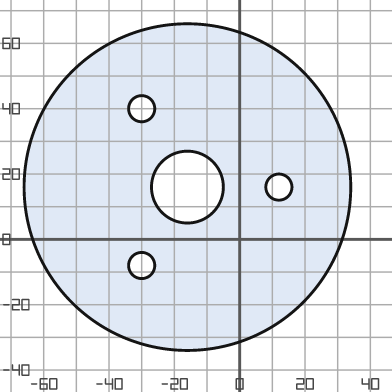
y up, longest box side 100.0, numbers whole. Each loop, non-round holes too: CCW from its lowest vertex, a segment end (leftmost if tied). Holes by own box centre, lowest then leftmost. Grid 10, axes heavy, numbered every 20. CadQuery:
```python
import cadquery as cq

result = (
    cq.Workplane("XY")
    .moveTo(-16.0, 16.0)
    .circle(50.0)
    .moveTo(-30.0, -8.0)
    .circle(4.0)
    .moveTo(-16.0, 16.0)
    .circle(11.0)
    .moveTo(12.0, 16.0)
    .circle(4.0)
    .moveTo(-30.0, 40.0)
    .circle(4.0)
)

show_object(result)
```